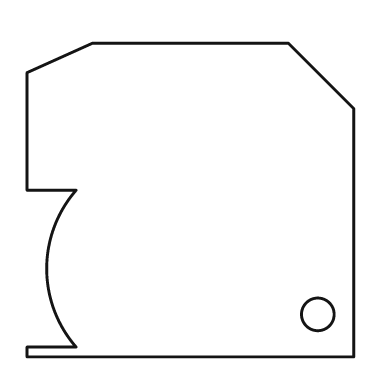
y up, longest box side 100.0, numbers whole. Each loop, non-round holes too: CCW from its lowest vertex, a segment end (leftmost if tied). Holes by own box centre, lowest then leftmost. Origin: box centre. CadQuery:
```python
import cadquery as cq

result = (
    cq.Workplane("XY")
    .moveTo(-50.0, -48.0)
    .lineTo(50.0, -48.0)
    .lineTo(50.0, 28.0)
    .lineTo(30.0, 48.0)
    .lineTo(-30.0, 48.0)
    .lineTo(-50.0, 39.0)
    .lineTo(-50.0, 3.0)
    .lineTo(-35.0, 3.0)
    .threePointArc((-44.0, -21.0), (-35.0, -45.0))
    .lineTo(-50.0, -45.0)
    .close()
    .moveTo(39.0, -35.0)
    .circle(5.0)
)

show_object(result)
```